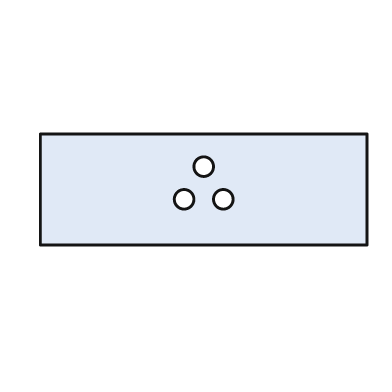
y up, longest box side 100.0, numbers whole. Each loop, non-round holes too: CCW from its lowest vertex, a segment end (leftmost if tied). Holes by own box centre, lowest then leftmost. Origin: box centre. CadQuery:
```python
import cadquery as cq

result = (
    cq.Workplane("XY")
    .moveTo(-50.0, -17.0)
    .lineTo(50.0, -17.0)
    .lineTo(50.0, 17.0)
    .lineTo(-50.0, 17.0)
    .close()
    .moveTo(-6.0, -3.0)
    .circle(3.0)
    .moveTo(6.0, -3.0)
    .circle(3.0)
    .moveTo(0.0, 7.0)
    .circle(3.0)
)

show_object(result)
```